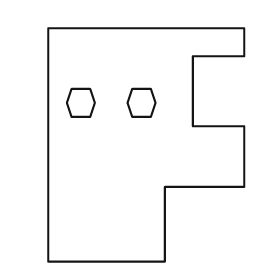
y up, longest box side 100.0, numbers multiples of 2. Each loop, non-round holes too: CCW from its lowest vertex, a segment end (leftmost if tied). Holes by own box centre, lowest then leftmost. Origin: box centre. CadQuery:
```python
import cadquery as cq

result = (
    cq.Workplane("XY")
    .moveTo(-42.0, -50.0)
    .lineTo(8.0, -50.0)
    .lineTo(8.0, -18.0)
    .lineTo(42.0, -18.0)
    .lineTo(42.0, 8.0)
    .lineTo(20.0, 8.0)
    .lineTo(20.0, 38.0)
    .lineTo(42.0, 38.0)
    .lineTo(42.0, 50.0)
    .lineTo(-42.0, 50.0)
    .close()
    .moveTo(-32.0, 12.0)
    .lineTo(-24.0, 12.0)
    .lineTo(-22.0, 18.0)
    .lineTo(-24.0, 24.0)
    .lineTo(-32.0, 24.0)
    .lineTo(-34.0, 18.0)
    .close()
    .moveTo(-6.0, 12.0)
    .lineTo(2.0, 12.0)
    .lineTo(4.0, 18.0)
    .lineTo(2.0, 24.0)
    .lineTo(-6.0, 24.0)
    .lineTo(-8.0, 18.0)
    .close()
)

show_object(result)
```